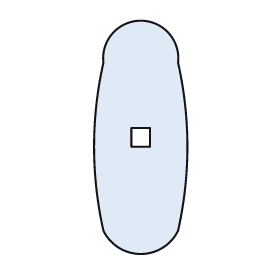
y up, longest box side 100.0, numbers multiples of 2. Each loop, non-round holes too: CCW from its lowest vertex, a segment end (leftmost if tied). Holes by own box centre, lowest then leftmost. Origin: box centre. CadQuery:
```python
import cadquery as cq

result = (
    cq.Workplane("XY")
    .moveTo(-16.0, -40.0)
    .threePointArc((0.0, -50.0), (16.0, -40.0))
    .threePointArc((20.0, -4.0), (16.0, 32.0))
    .threePointArc((0.0, 50.0), (-16.0, 32.0))
    .threePointArc((-20.0, -4.0), (-16.0, -40.0))
    .close()
    .moveTo(-4.0, -4.0)
    .lineTo(4.0, -4.0)
    .lineTo(4.0, 4.0)
    .lineTo(-4.0, 4.0)
    .close()
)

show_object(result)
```